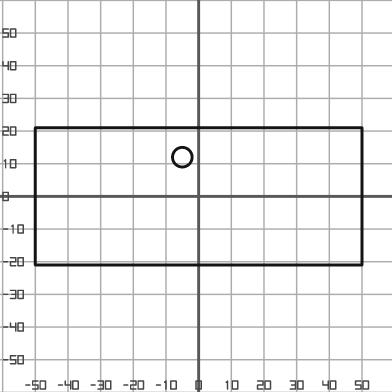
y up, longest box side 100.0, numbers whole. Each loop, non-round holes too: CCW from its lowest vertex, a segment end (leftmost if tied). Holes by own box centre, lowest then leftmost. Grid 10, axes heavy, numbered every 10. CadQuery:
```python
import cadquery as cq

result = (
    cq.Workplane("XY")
    .moveTo(-50.0, -21.0)
    .lineTo(50.0, -21.0)
    .lineTo(50.0, 21.0)
    .lineTo(-50.0, 21.0)
    .close()
    .moveTo(-5.0, 12.0)
    .circle(3.0)
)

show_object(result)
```